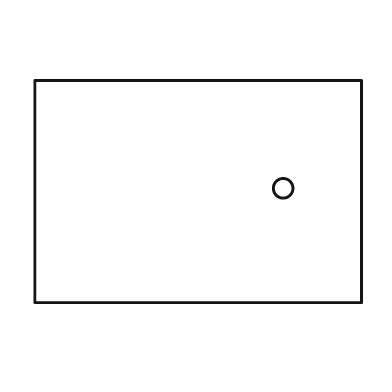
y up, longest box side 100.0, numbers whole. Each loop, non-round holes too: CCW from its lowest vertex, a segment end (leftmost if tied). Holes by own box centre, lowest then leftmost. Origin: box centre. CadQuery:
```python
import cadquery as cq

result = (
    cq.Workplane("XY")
    .moveTo(-50.0, -34.0)
    .lineTo(50.0, -34.0)
    .lineTo(50.0, 34.0)
    .lineTo(-50.0, 34.0)
    .close()
    .moveTo(26.0, 1.0)
    .circle(3.0)
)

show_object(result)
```